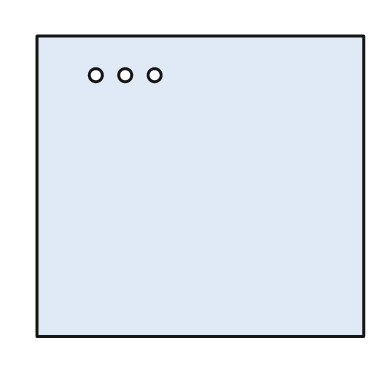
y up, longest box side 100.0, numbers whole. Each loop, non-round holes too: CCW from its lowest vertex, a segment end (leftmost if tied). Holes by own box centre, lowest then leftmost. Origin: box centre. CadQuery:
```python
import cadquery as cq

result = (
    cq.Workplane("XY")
    .moveTo(-50.0, -46.0)
    .lineTo(50.0, -46.0)
    .lineTo(50.0, 46.0)
    .lineTo(-50.0, 46.0)
    .close()
    .moveTo(-32.0, 34.0)
    .circle(2.0)
    .moveTo(-23.0, 34.0)
    .circle(2.0)
    .moveTo(-14.0, 34.0)
    .circle(2.0)
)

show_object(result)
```